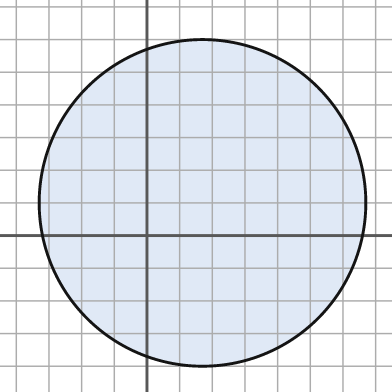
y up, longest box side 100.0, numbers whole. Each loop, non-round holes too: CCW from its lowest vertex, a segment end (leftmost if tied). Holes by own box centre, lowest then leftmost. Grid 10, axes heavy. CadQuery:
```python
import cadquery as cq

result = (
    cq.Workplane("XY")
    .moveTo(17.0, 10.0)
    .circle(50.0)
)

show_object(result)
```